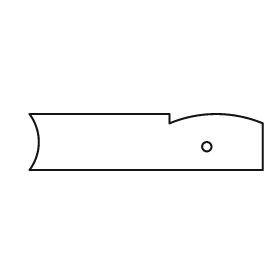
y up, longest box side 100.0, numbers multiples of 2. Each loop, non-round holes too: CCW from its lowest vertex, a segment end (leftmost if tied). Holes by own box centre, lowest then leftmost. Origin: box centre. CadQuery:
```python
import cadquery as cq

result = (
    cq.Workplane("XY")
    .moveTo(-50.0, -12.0)
    .lineTo(50.0, -12.0)
    .lineTo(50.0, 8.0)
    .threePointArc((30.0, 12.0), (10.0, 8.0))
    .lineTo(10.0, 12.0)
    .lineTo(-50.0, 12.0)
    .threePointArc((-46.0, 0.0), (-50.0, -12.0))
    .close()
    .moveTo(26.0, -2.0)
    .circle(2.0)
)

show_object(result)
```